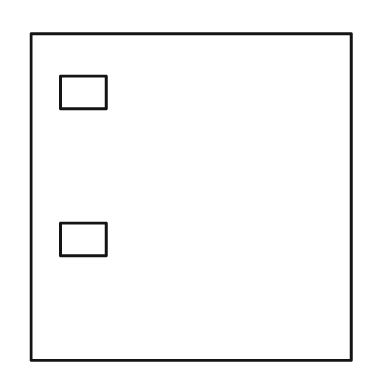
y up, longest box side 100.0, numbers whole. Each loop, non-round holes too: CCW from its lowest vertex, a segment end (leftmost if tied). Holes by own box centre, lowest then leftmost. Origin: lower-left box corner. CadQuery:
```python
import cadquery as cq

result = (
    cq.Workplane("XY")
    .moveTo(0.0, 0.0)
    .lineTo(98.0, 0.0)
    .lineTo(98.0, 100.0)
    .lineTo(0.0, 100.0)
    .close()
    .moveTo(9.0, 32.0)
    .lineTo(23.0, 32.0)
    .lineTo(23.0, 42.0)
    .lineTo(9.0, 42.0)
    .close()
    .moveTo(9.0, 77.0)
    .lineTo(23.0, 77.0)
    .lineTo(23.0, 87.0)
    .lineTo(9.0, 87.0)
    .close()
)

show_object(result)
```